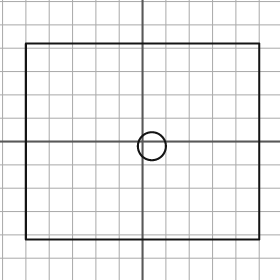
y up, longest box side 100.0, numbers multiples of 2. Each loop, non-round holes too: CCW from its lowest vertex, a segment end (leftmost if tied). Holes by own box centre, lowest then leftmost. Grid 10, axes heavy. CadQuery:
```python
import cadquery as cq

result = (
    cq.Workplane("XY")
    .moveTo(-50.0, -42.0)
    .lineTo(50.0, -42.0)
    .lineTo(50.0, 42.0)
    .lineTo(-50.0, 42.0)
    .close()
    .moveTo(4.0, -2.0)
    .circle(6.0)
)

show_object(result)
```